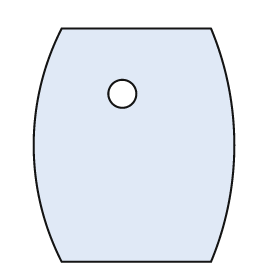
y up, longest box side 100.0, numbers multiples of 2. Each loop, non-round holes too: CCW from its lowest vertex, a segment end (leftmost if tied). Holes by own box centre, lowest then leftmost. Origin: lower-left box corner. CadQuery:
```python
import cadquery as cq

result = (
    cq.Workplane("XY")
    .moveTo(12.0, 0.0)
    .lineTo(76.0, 0.0)
    .threePointArc((86.0, 50.0), (76.0, 100.0))
    .lineTo(12.0, 100.0)
    .threePointArc((0.0, 50.0), (12.0, 0.0))
    .close()
    .moveTo(38.0, 72.0)
    .circle(6.0)
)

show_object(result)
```